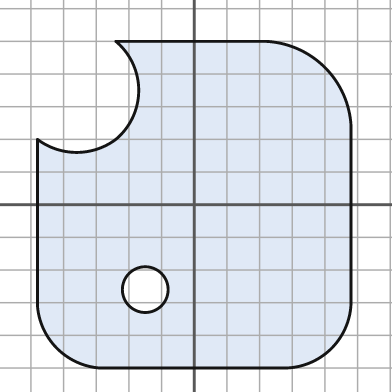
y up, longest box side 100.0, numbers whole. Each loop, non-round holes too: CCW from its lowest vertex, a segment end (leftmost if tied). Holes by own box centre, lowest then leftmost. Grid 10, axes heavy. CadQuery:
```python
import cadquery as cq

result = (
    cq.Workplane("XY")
    .moveTo(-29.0, -50.0)
    .lineTo(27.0, -50.0)
    .threePointArc((42.0, -44.0), (48.0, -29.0))
    .lineTo(48.0, 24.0)
    .threePointArc((40.0, 42.0), (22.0, 50.0))
    .lineTo(-24.0, 50.0)
    .threePointArc((-17.0, 35.0), (-24.0, 20.0))
    .threePointArc((-36.0, 16.0), (-48.0, 20.0))
    .lineTo(-48.0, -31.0)
    .threePointArc((-42.0, -44.0), (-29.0, -50.0))
    .close()
    .moveTo(-15.0, -26.0)
    .circle(7.0)
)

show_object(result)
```